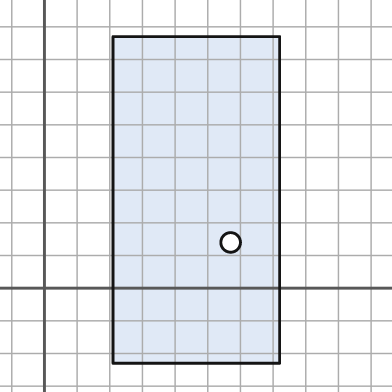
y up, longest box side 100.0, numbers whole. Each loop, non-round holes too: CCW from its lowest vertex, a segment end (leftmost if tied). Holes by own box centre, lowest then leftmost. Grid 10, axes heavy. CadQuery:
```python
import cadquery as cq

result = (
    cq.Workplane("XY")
    .moveTo(21.0, -23.0)
    .lineTo(72.0, -23.0)
    .lineTo(72.0, 77.0)
    .lineTo(21.0, 77.0)
    .close()
    .moveTo(57.0, 14.0)
    .circle(3.0)
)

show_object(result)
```